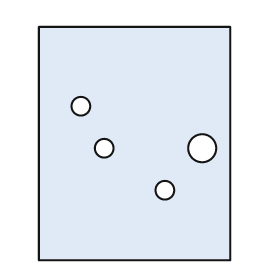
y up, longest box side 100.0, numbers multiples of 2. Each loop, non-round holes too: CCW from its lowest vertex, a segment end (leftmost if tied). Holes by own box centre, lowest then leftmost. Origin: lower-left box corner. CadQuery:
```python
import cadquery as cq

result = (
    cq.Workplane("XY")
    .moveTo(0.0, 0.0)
    .lineTo(82.0, 0.0)
    .lineTo(82.0, 100.0)
    .lineTo(0.0, 100.0)
    .close()
    .moveTo(54.0, 30.0)
    .circle(4.0)
    .moveTo(28.0, 48.0)
    .circle(4.0)
    .moveTo(70.0, 48.0)
    .circle(6.0)
    .moveTo(18.0, 66.0)
    .circle(4.0)
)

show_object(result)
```